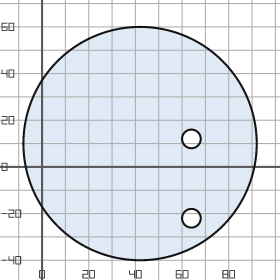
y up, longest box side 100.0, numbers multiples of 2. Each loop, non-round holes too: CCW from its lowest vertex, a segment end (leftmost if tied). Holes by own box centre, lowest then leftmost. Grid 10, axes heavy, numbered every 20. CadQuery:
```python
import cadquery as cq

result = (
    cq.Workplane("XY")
    .moveTo(42.0, 10.0)
    .circle(50.0)
    .moveTo(64.0, -22.0)
    .circle(4.0)
    .moveTo(64.0, 12.0)
    .circle(4.0)
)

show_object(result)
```